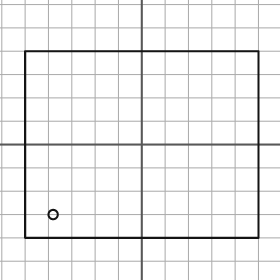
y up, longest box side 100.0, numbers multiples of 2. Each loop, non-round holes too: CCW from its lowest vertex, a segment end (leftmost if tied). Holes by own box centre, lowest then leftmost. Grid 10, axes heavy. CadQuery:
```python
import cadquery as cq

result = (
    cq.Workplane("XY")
    .moveTo(-50.0, -40.0)
    .lineTo(50.0, -40.0)
    .lineTo(50.0, 40.0)
    .lineTo(-50.0, 40.0)
    .close()
    .moveTo(-38.0, -30.0)
    .circle(2.0)
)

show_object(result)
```